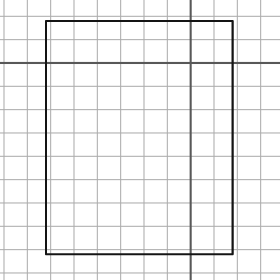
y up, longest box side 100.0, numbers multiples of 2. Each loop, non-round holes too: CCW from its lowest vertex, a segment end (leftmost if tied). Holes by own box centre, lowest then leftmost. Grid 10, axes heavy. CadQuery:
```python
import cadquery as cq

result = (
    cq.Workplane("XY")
    .moveTo(-62.0, -82.0)
    .lineTo(18.0, -82.0)
    .lineTo(18.0, 18.0)
    .lineTo(-62.0, 18.0)
    .close()
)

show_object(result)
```